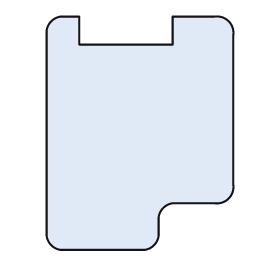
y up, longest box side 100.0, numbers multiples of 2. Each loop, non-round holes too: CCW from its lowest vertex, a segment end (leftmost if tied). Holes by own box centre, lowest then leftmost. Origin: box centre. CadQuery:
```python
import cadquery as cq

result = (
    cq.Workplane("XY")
    .moveTo(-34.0, -50.0)
    .lineTo(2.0, -50.0)
    .threePointArc((6.0, -48.0), (8.0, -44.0))
    .lineTo(8.0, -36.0)
    .threePointArc((10.0, -32.0), (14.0, -30.0))
    .lineTo(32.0, -30.0)
    .threePointArc((38.0, -28.0), (40.0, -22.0))
    .lineTo(40.0, 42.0)
    .threePointArc((38.0, 48.0), (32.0, 50.0))
    .lineTo(14.0, 50.0)
    .lineTo(14.0, 38.0)
    .lineTo(-26.0, 38.0)
    .lineTo(-26.0, 50.0)
    .lineTo(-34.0, 50.0)
    .threePointArc((-38.0, 48.0), (-40.0, 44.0))
    .lineTo(-40.0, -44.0)
    .threePointArc((-38.0, -48.0), (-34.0, -50.0))
    .close()
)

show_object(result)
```